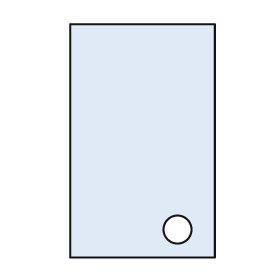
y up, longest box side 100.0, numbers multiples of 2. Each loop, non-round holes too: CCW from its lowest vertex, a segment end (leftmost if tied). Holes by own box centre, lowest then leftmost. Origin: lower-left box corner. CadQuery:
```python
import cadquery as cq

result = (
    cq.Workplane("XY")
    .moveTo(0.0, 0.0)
    .lineTo(62.0, 0.0)
    .lineTo(62.0, 100.0)
    .lineTo(0.0, 100.0)
    .close()
    .moveTo(46.0, 12.0)
    .circle(6.0)
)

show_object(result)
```